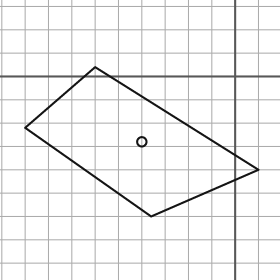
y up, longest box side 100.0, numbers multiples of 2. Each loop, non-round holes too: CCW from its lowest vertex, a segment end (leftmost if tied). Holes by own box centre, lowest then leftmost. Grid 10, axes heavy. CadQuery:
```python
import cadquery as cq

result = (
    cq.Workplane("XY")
    .moveTo(-36.0, -60.0)
    .lineTo(10.0, -40.0)
    .lineTo(-60.0, 4.0)
    .lineTo(-90.0, -22.0)
    .close()
    .moveTo(-40.0, -28.0)
    .circle(2.0)
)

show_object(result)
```